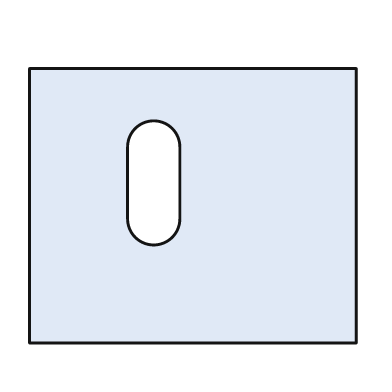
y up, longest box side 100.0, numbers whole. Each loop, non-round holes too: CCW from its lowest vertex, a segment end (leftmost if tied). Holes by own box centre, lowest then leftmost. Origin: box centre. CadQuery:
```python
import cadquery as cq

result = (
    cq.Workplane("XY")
    .moveTo(-50.0, -42.0)
    .lineTo(50.0, -42.0)
    .lineTo(50.0, 42.0)
    .lineTo(-50.0, 42.0)
    .close()
    .moveTo(-20.0, -4.0)
    .threePointArc((-12.0, -12.0), (-4.0, -4.0))
    .lineTo(-4.0, 18.0)
    .threePointArc((-12.0, 26.0), (-20.0, 18.0))
    .close()
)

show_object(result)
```